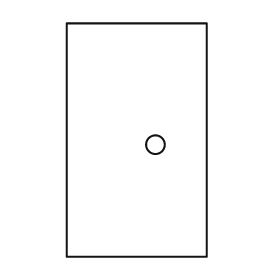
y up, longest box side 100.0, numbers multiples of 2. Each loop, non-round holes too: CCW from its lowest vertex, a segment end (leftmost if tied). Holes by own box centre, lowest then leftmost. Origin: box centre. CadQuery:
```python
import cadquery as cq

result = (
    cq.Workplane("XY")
    .moveTo(-30.0, -50.0)
    .lineTo(30.0, -50.0)
    .lineTo(30.0, 50.0)
    .lineTo(-30.0, 50.0)
    .close()
    .moveTo(8.0, -2.0)
    .circle(4.0)
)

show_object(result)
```